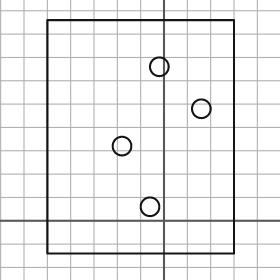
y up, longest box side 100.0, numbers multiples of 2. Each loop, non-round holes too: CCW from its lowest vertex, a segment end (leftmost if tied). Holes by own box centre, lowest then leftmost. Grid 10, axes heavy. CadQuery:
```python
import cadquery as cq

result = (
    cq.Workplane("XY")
    .moveTo(-50.0, -14.0)
    .lineTo(30.0, -14.0)
    .lineTo(30.0, 86.0)
    .lineTo(-50.0, 86.0)
    .close()
    .moveTo(-6.0, 6.0)
    .circle(4.0)
    .moveTo(-18.0, 32.0)
    .circle(4.0)
    .moveTo(16.0, 48.0)
    .circle(4.0)
    .moveTo(-2.0, 66.0)
    .circle(4.0)
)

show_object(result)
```